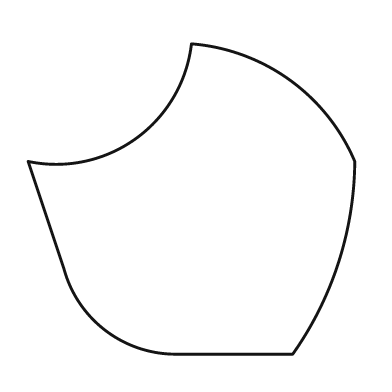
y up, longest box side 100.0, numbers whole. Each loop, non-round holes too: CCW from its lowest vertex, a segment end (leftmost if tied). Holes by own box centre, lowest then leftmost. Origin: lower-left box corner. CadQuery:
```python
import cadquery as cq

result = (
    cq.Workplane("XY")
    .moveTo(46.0, 0.0)
    .lineTo(81.0, 0.0)
    .threePointArc((95.0, 28.0), (100.0, 59.0))
    .threePointArc((80.0, 84.0), (50.0, 95.0))
    .threePointArc((33.0, 66.0), (0.0, 59.0))
    .lineTo(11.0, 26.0)
    .threePointArc((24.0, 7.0), (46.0, 0.0))
    .close()
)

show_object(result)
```